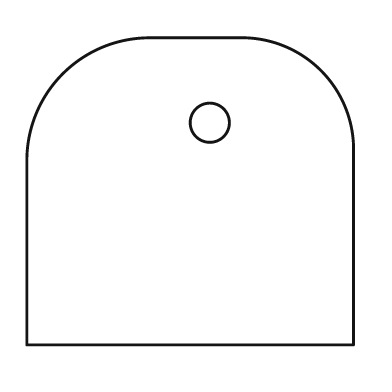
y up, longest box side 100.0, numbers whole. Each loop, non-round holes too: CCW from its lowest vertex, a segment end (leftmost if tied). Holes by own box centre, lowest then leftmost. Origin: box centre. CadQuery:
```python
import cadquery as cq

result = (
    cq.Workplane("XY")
    .moveTo(-50.0, -47.0)
    .lineTo(50.0, -47.0)
    .lineTo(50.0, 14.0)
    .threePointArc((40.0, 37.0), (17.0, 47.0))
    .lineTo(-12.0, 47.0)
    .threePointArc((-39.0, 36.0), (-50.0, 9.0))
    .close()
    .moveTo(6.0, 21.0)
    .circle(6.0)
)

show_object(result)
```